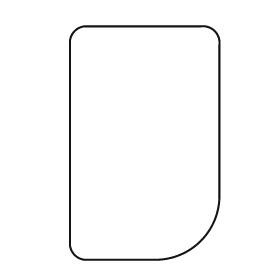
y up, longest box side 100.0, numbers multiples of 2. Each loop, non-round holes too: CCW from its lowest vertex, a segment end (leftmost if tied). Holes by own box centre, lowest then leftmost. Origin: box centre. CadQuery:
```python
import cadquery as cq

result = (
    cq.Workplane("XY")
    .moveTo(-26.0, -50.0)
    .lineTo(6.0, -50.0)
    .threePointArc((24.0, -42.0), (32.0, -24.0))
    .lineTo(32.0, 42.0)
    .threePointArc((30.0, 48.0), (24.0, 50.0))
    .lineTo(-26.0, 50.0)
    .threePointArc((-30.0, 48.0), (-32.0, 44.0))
    .lineTo(-32.0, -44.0)
    .threePointArc((-30.0, -48.0), (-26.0, -50.0))
    .close()
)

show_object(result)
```